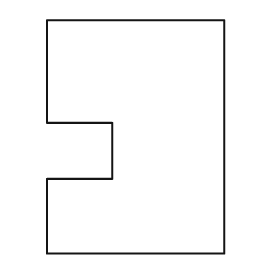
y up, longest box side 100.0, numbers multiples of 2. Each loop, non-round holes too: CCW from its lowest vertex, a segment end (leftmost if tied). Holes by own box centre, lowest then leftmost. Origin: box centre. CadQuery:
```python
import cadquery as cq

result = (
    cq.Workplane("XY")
    .moveTo(-38.0, -50.0)
    .lineTo(38.0, -50.0)
    .lineTo(38.0, 50.0)
    .lineTo(-38.0, 50.0)
    .lineTo(-38.0, 6.0)
    .lineTo(-10.0, 6.0)
    .lineTo(-10.0, -18.0)
    .lineTo(-38.0, -18.0)
    .close()
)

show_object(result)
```